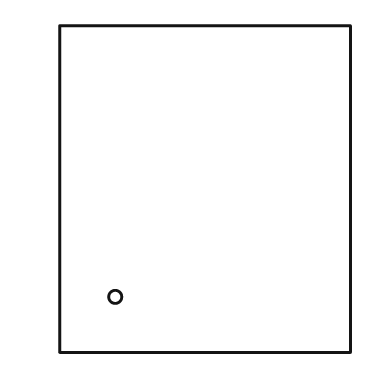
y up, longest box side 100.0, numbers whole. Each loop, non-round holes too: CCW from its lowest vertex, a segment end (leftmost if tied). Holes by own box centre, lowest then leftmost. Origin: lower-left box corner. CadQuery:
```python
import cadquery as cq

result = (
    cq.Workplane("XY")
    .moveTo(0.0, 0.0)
    .lineTo(89.0, 0.0)
    .lineTo(89.0, 100.0)
    .lineTo(0.0, 100.0)
    .close()
    .moveTo(17.0, 17.0)
    .circle(2.0)
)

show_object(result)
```